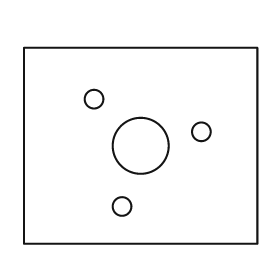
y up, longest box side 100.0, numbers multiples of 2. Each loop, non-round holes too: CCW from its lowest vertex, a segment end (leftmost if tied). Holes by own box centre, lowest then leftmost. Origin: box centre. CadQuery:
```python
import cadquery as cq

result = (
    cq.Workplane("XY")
    .moveTo(-50.0, -42.0)
    .lineTo(50.0, -42.0)
    .lineTo(50.0, 42.0)
    .lineTo(-50.0, 42.0)
    .close()
    .moveTo(-8.0, -26.0)
    .circle(4.0)
    .moveTo(0.0, 0.0)
    .circle(12.0)
    .moveTo(26.0, 6.0)
    .circle(4.0)
    .moveTo(-20.0, 20.0)
    .circle(4.0)
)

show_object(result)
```